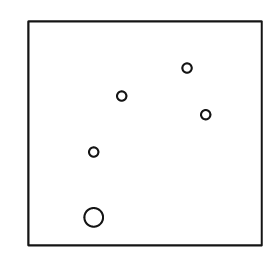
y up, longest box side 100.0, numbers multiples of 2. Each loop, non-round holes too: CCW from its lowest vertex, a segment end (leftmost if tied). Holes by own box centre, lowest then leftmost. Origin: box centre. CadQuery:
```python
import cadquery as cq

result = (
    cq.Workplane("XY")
    .moveTo(-50.0, -48.0)
    .lineTo(50.0, -48.0)
    .lineTo(50.0, 48.0)
    .lineTo(-50.0, 48.0)
    .close()
    .moveTo(-22.0, -36.0)
    .circle(4.0)
    .moveTo(-22.0, -8.0)
    .circle(2.0)
    .moveTo(26.0, 8.0)
    .circle(2.0)
    .moveTo(-10.0, 16.0)
    .circle(2.0)
    .moveTo(18.0, 28.0)
    .circle(2.0)
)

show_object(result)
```